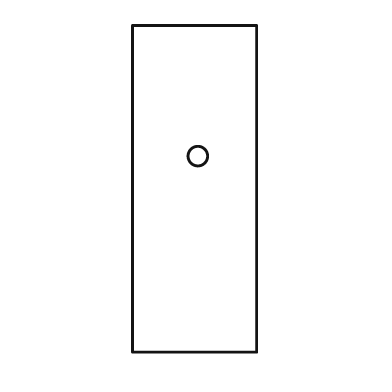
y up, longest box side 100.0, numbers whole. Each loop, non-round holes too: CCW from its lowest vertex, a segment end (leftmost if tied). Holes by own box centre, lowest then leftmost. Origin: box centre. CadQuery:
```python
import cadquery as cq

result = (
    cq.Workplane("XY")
    .moveTo(-19.0, -50.0)
    .lineTo(19.0, -50.0)
    .lineTo(19.0, 50.0)
    .lineTo(-19.0, 50.0)
    .close()
    .moveTo(1.0, 10.0)
    .circle(3.0)
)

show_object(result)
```